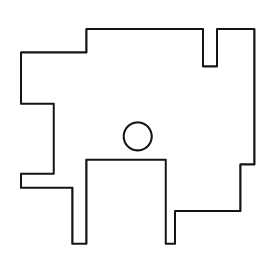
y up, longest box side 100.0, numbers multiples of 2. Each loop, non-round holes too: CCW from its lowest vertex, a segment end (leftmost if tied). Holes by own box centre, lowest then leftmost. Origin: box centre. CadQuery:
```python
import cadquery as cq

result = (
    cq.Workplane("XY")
    .moveTo(-28.0, -46.0)
    .lineTo(-22.0, -46.0)
    .lineTo(-22.0, -10.0)
    .lineTo(12.0, -10.0)
    .lineTo(12.0, -46.0)
    .lineTo(16.0, -46.0)
    .lineTo(16.0, -32.0)
    .lineTo(44.0, -32.0)
    .lineTo(44.0, -12.0)
    .lineTo(50.0, -12.0)
    .lineTo(50.0, 46.0)
    .lineTo(34.0, 46.0)
    .lineTo(34.0, 30.0)
    .lineTo(28.0, 30.0)
    .lineTo(28.0, 46.0)
    .lineTo(-22.0, 46.0)
    .lineTo(-22.0, 36.0)
    .lineTo(-50.0, 36.0)
    .lineTo(-50.0, 14.0)
    .lineTo(-36.0, 14.0)
    .lineTo(-36.0, -16.0)
    .lineTo(-50.0, -16.0)
    .lineTo(-50.0, -22.0)
    .lineTo(-28.0, -22.0)
    .close()
    .moveTo(0.0, 0.0)
    .circle(6.0)
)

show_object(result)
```